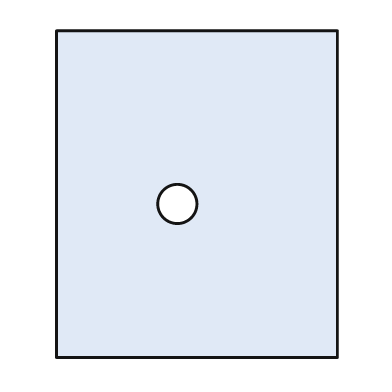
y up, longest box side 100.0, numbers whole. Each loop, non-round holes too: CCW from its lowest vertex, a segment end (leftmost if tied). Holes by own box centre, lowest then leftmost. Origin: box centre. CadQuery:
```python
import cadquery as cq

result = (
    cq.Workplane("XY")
    .moveTo(-43.0, -50.0)
    .lineTo(43.0, -50.0)
    .lineTo(43.0, 50.0)
    .lineTo(-43.0, 50.0)
    .close()
    .moveTo(-6.0, -3.0)
    .circle(6.0)
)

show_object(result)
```